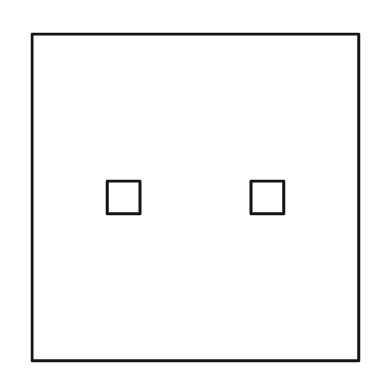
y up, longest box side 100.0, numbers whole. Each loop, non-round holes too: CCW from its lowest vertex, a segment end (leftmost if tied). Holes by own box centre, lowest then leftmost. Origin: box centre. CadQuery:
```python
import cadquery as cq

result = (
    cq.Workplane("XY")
    .moveTo(-50.0, -50.0)
    .lineTo(50.0, -50.0)
    .lineTo(50.0, 50.0)
    .lineTo(-50.0, 50.0)
    .close()
    .moveTo(-27.0, -5.0)
    .lineTo(-17.0, -5.0)
    .lineTo(-17.0, 5.0)
    .lineTo(-27.0, 5.0)
    .close()
    .moveTo(17.0, -5.0)
    .lineTo(27.0, -5.0)
    .lineTo(27.0, 5.0)
    .lineTo(17.0, 5.0)
    .close()
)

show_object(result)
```